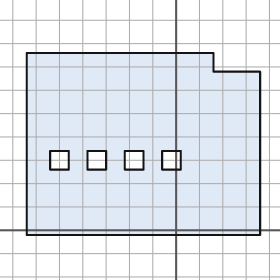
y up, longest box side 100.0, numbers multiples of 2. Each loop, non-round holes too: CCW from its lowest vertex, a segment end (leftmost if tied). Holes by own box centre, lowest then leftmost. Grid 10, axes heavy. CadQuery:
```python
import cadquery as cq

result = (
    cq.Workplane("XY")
    .moveTo(-64.0, -2.0)
    .lineTo(36.0, -2.0)
    .lineTo(36.0, 68.0)
    .lineTo(16.0, 68.0)
    .lineTo(16.0, 76.0)
    .lineTo(-64.0, 76.0)
    .close()
    .moveTo(-54.0, 26.0)
    .lineTo(-46.0, 26.0)
    .lineTo(-46.0, 34.0)
    .lineTo(-54.0, 34.0)
    .close()
    .moveTo(-38.0, 26.0)
    .lineTo(-30.0, 26.0)
    .lineTo(-30.0, 34.0)
    .lineTo(-38.0, 34.0)
    .close()
    .moveTo(-22.0, 26.0)
    .lineTo(-14.0, 26.0)
    .lineTo(-14.0, 34.0)
    .lineTo(-22.0, 34.0)
    .close()
    .moveTo(-6.0, 26.0)
    .lineTo(2.0, 26.0)
    .lineTo(2.0, 34.0)
    .lineTo(-6.0, 34.0)
    .close()
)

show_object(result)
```